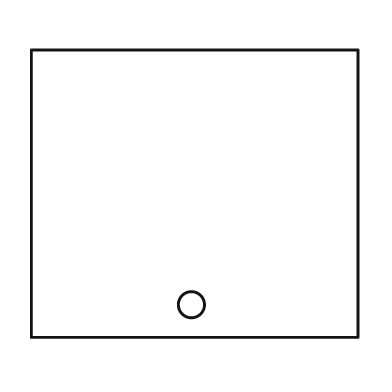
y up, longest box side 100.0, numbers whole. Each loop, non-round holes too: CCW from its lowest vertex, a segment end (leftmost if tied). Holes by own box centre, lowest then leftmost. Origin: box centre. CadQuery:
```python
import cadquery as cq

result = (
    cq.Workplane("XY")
    .moveTo(-50.0, -44.0)
    .lineTo(50.0, -44.0)
    .lineTo(50.0, 44.0)
    .lineTo(-50.0, 44.0)
    .close()
    .moveTo(-1.0, -34.0)
    .circle(4.0)
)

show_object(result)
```